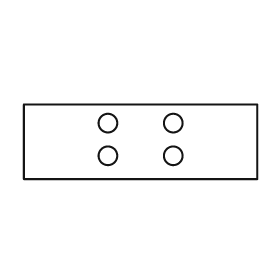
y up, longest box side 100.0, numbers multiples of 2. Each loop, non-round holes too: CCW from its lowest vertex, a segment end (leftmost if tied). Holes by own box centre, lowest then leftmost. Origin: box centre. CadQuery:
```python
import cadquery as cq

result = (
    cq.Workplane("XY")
    .moveTo(-50.0, -16.0)
    .lineTo(50.0, -16.0)
    .lineTo(50.0, 16.0)
    .lineTo(-50.0, 16.0)
    .close()
    .moveTo(-14.0, -6.0)
    .circle(4.0)
    .moveTo(14.0, -6.0)
    .circle(4.0)
    .moveTo(-14.0, 8.0)
    .circle(4.0)
    .moveTo(14.0, 8.0)
    .circle(4.0)
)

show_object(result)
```